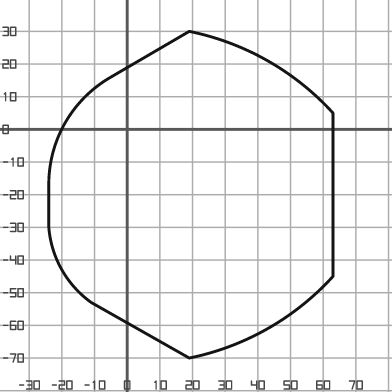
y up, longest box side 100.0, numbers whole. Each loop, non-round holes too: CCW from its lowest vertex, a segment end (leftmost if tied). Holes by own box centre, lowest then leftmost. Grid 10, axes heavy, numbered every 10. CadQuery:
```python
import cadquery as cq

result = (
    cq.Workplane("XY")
    .moveTo(19.0, -70.0)
    .threePointArc((43.0, -61.0), (63.0, -45.0))
    .lineTo(63.0, 5.0)
    .threePointArc((43.0, 21.0), (19.0, 30.0))
    .lineTo(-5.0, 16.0)
    .threePointArc((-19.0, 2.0), (-24.0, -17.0))
    .lineTo(-24.0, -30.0)
    .threePointArc((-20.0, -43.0), (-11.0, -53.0))
    .close()
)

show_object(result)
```